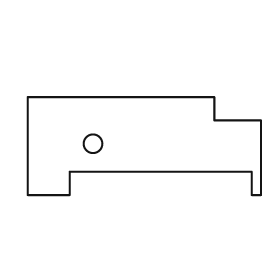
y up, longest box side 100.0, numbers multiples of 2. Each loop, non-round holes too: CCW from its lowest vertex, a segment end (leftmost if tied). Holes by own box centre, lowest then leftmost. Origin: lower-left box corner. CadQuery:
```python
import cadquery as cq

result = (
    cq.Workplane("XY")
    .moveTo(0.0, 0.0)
    .lineTo(18.0, 0.0)
    .lineTo(18.0, 10.0)
    .lineTo(96.0, 10.0)
    .lineTo(96.0, 0.0)
    .lineTo(100.0, 0.0)
    .lineTo(100.0, 32.0)
    .lineTo(80.0, 32.0)
    .lineTo(80.0, 42.0)
    .lineTo(0.0, 42.0)
    .close()
    .moveTo(28.0, 22.0)
    .circle(4.0)
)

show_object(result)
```